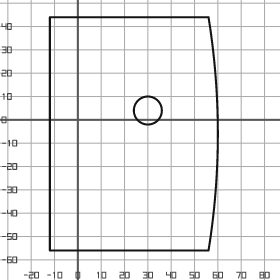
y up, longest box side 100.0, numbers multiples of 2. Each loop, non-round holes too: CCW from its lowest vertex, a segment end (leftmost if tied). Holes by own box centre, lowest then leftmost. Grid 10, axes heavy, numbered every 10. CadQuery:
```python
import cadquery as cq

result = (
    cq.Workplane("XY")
    .moveTo(-12.0, -56.0)
    .lineTo(56.0, -56.0)
    .threePointArc((60.0, -6.0), (56.0, 44.0))
    .lineTo(-12.0, 44.0)
    .close()
    .moveTo(30.0, 4.0)
    .circle(6.0)
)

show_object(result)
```